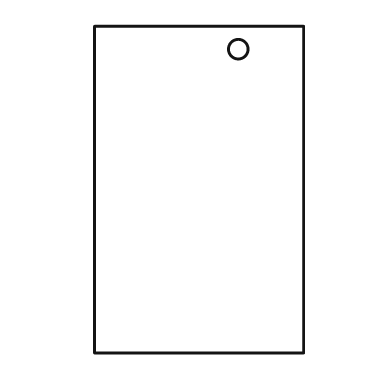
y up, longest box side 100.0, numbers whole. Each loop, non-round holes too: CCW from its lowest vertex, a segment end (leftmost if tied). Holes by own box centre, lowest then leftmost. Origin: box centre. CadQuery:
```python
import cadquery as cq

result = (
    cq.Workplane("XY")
    .moveTo(-32.0, -50.0)
    .lineTo(32.0, -50.0)
    .lineTo(32.0, 50.0)
    .lineTo(-32.0, 50.0)
    .close()
    .moveTo(12.0, 43.0)
    .circle(3.0)
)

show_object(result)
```